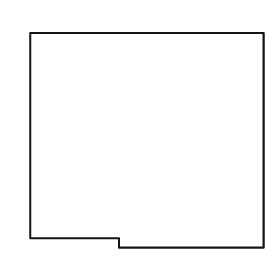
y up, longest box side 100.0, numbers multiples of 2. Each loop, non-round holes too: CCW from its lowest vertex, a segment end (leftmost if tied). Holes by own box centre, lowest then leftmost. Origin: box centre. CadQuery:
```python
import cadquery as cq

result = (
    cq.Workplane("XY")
    .moveTo(-12.0, -46.0)
    .lineTo(50.0, -46.0)
    .lineTo(50.0, 46.0)
    .lineTo(-50.0, 46.0)
    .lineTo(-50.0, -42.0)
    .lineTo(-12.0, -42.0)
    .close()
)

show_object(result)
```